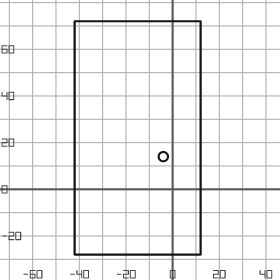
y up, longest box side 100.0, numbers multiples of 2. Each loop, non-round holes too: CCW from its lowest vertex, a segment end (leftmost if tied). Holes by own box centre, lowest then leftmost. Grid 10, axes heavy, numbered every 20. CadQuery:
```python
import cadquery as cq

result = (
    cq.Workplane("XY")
    .moveTo(-42.0, -28.0)
    .lineTo(12.0, -28.0)
    .lineTo(12.0, 72.0)
    .lineTo(-42.0, 72.0)
    .close()
    .moveTo(-4.0, 14.0)
    .circle(2.0)
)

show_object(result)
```